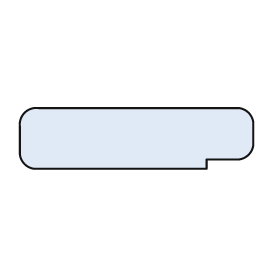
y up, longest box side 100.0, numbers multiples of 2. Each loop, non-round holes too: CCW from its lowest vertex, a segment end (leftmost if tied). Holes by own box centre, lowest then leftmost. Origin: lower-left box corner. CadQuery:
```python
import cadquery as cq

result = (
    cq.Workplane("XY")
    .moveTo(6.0, 0.0)
    .lineTo(80.0, 0.0)
    .lineTo(80.0, 4.0)
    .lineTo(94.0, 4.0)
    .threePointArc((98.0, 6.0), (100.0, 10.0))
    .lineTo(100.0, 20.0)
    .threePointArc((98.0, 24.0), (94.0, 26.0))
    .lineTo(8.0, 26.0)
    .threePointArc((2.0, 24.0), (0.0, 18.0))
    .lineTo(0.0, 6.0)
    .threePointArc((2.0, 2.0), (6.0, 0.0))
    .close()
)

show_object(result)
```